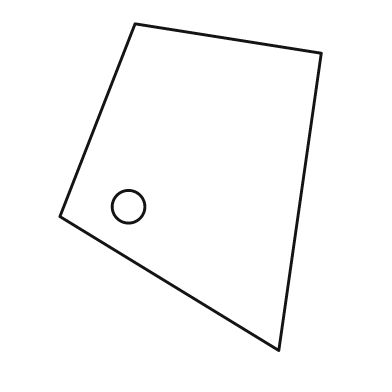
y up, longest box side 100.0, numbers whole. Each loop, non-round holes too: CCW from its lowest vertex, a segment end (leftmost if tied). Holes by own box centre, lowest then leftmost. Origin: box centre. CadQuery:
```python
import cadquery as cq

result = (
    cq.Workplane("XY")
    .moveTo(27.0, -50.0)
    .lineTo(40.0, 41.0)
    .lineTo(-17.0, 50.0)
    .lineTo(-40.0, -9.0)
    .close()
    .moveTo(-19.0, -6.0)
    .circle(5.0)
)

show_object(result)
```